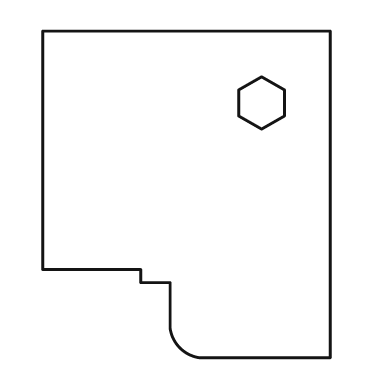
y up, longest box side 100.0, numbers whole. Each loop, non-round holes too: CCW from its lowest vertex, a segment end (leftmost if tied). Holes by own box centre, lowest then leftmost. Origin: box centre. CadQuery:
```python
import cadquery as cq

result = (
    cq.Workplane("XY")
    .moveTo(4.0, -50.0)
    .lineTo(44.0, -50.0)
    .lineTo(44.0, 50.0)
    .lineTo(-44.0, 50.0)
    .lineTo(-44.0, -23.0)
    .lineTo(-14.0, -23.0)
    .lineTo(-14.0, -27.0)
    .lineTo(-5.0, -27.0)
    .lineTo(-5.0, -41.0)
    .threePointArc((-2.0, -47.0), (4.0, -50.0))
    .close()
    .moveTo(23.0, 20.0)
    .lineTo(30.0, 24.0)
    .lineTo(30.0, 32.0)
    .lineTo(23.0, 36.0)
    .lineTo(16.0, 32.0)
    .lineTo(16.0, 24.0)
    .close()
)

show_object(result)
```